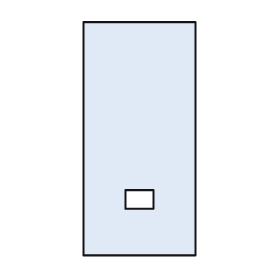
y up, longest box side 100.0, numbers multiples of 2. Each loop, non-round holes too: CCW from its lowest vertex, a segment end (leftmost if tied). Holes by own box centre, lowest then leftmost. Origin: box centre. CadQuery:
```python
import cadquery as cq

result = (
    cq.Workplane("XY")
    .moveTo(-24.0, -50.0)
    .lineTo(24.0, -50.0)
    .lineTo(24.0, 50.0)
    .lineTo(-24.0, 50.0)
    .close()
    .moveTo(-6.0, -30.0)
    .lineTo(6.0, -30.0)
    .lineTo(6.0, -22.0)
    .lineTo(-6.0, -22.0)
    .close()
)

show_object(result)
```